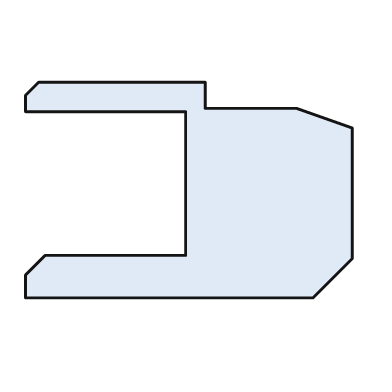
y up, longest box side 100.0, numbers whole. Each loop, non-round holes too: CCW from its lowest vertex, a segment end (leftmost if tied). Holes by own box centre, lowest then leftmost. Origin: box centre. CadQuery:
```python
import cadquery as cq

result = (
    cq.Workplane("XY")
    .moveTo(-50.0, -33.0)
    .lineTo(38.0, -33.0)
    .lineTo(50.0, -21.0)
    .lineTo(50.0, 19.0)
    .lineTo(33.0, 25.0)
    .lineTo(5.0, 25.0)
    .lineTo(5.0, 33.0)
    .lineTo(-46.0, 33.0)
    .lineTo(-50.0, 29.0)
    .lineTo(-50.0, 24.0)
    .lineTo(-1.0, 24.0)
    .lineTo(-1.0, -20.0)
    .lineTo(-44.0, -20.0)
    .lineTo(-50.0, -26.0)
    .close()
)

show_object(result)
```